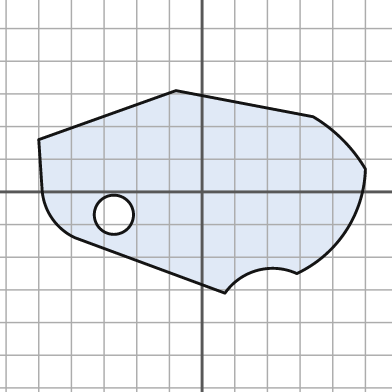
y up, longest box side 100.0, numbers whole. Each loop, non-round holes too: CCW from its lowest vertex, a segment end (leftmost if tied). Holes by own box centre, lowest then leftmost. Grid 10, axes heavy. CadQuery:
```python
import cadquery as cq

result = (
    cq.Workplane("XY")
    .moveTo(7.0, -31.0)
    .threePointArc((17.0, -24.0), (29.0, -25.0))
    .threePointArc((44.0, -12.0), (50.0, 7.0))
    .threePointArc((43.0, 16.0), (34.0, 23.0))
    .lineTo(-8.0, 31.0)
    .lineTo(-50.0, 16.0)
    .lineTo(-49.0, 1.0)
    .threePointArc((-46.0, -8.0), (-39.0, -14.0))
    .close()
    .moveTo(-27.0, -7.0)
    .circle(6.0)
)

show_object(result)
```